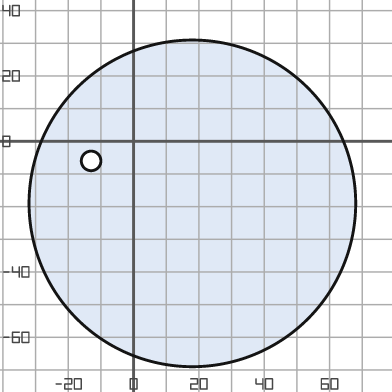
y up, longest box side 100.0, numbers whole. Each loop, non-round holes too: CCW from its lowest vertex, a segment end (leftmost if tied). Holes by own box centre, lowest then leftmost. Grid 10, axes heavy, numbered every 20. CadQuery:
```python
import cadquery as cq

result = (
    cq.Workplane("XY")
    .moveTo(18.0, -19.0)
    .circle(50.0)
    .moveTo(-13.0, -6.0)
    .circle(3.0)
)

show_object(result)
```